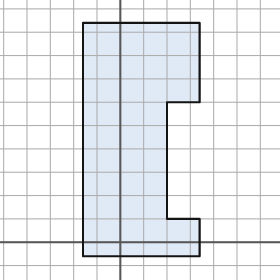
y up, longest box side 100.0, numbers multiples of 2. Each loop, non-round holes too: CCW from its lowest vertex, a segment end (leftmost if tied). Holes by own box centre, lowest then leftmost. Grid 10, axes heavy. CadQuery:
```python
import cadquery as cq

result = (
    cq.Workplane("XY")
    .moveTo(-16.0, -6.0)
    .lineTo(34.0, -6.0)
    .lineTo(34.0, 10.0)
    .lineTo(20.0, 10.0)
    .lineTo(20.0, 60.0)
    .lineTo(34.0, 60.0)
    .lineTo(34.0, 94.0)
    .lineTo(-16.0, 94.0)
    .close()
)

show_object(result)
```